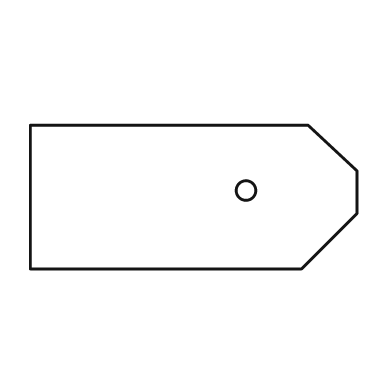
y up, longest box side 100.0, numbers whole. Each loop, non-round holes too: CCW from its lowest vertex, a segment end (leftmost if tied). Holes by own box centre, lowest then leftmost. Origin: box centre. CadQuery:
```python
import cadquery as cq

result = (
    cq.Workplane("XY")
    .moveTo(-50.0, -22.0)
    .lineTo(33.0, -22.0)
    .lineTo(50.0, -5.0)
    .lineTo(50.0, 8.0)
    .lineTo(35.0, 22.0)
    .lineTo(-50.0, 22.0)
    .close()
    .moveTo(16.0, 2.0)
    .circle(3.0)
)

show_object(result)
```